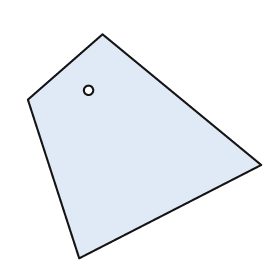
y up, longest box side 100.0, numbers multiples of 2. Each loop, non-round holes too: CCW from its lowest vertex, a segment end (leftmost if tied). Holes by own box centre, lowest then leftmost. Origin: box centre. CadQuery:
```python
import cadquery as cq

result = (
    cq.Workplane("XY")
    .moveTo(-28.0, -48.0)
    .lineTo(50.0, -8.0)
    .lineTo(-18.0, 48.0)
    .lineTo(-50.0, 20.0)
    .close()
    .moveTo(-24.0, 24.0)
    .circle(2.0)
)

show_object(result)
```